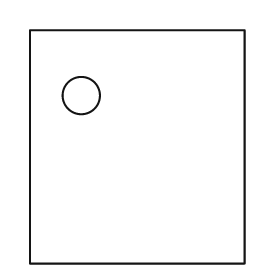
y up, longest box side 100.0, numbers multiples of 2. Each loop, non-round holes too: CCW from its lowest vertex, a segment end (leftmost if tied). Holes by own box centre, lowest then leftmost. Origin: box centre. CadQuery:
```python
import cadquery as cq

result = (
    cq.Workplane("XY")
    .moveTo(-46.0, -50.0)
    .lineTo(46.0, -50.0)
    .lineTo(46.0, 50.0)
    .lineTo(-46.0, 50.0)
    .close()
    .moveTo(-24.0, 22.0)
    .circle(8.0)
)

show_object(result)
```